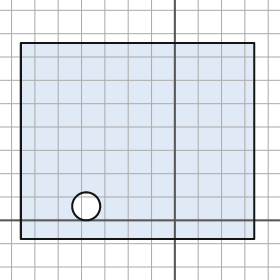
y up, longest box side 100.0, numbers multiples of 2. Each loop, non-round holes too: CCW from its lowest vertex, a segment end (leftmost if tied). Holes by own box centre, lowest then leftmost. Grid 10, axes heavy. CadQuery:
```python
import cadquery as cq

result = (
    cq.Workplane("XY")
    .moveTo(-66.0, -8.0)
    .lineTo(34.0, -8.0)
    .lineTo(34.0, 76.0)
    .lineTo(-66.0, 76.0)
    .close()
    .moveTo(-38.0, 6.0)
    .circle(6.0)
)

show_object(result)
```